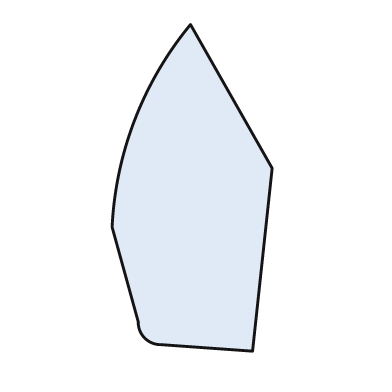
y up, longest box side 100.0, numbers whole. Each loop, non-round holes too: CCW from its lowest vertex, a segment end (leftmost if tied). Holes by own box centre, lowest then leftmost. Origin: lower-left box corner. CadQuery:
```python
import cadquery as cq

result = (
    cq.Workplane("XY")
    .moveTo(43.0, 0.0)
    .lineTo(49.0, 56.0)
    .lineTo(24.0, 100.0)
    .threePointArc((7.0, 71.0), (0.0, 38.0))
    .lineTo(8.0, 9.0)
    .threePointArc((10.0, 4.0), (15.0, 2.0))
    .close()
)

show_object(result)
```